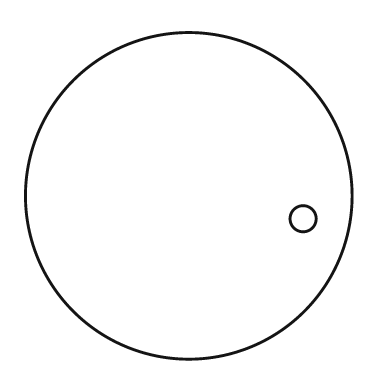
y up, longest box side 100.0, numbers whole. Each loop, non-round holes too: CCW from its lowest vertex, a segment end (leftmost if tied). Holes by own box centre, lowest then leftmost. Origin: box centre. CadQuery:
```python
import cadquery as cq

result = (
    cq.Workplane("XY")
    .moveTo(0.0, 0.0)
    .circle(50.0)
    .moveTo(35.0, -7.0)
    .circle(4.0)
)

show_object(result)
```